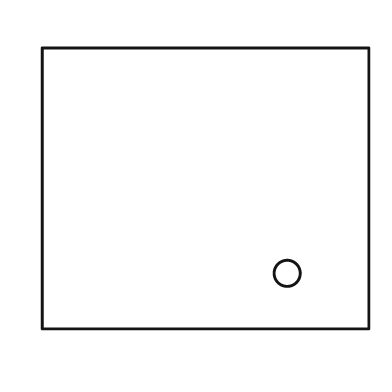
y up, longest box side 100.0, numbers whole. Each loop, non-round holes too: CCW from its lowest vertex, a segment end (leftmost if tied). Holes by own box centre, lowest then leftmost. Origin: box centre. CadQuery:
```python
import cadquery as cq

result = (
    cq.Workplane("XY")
    .moveTo(-50.0, -43.0)
    .lineTo(50.0, -43.0)
    .lineTo(50.0, 43.0)
    .lineTo(-50.0, 43.0)
    .close()
    .moveTo(25.0, -26.0)
    .circle(4.0)
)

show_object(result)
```